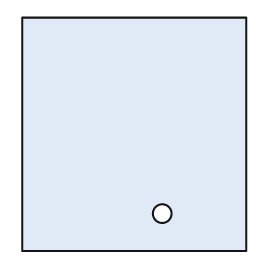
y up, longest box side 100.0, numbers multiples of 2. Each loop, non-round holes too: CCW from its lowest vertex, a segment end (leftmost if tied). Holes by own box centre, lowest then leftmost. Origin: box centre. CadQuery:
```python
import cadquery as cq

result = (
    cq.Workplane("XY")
    .moveTo(-48.0, -50.0)
    .lineTo(48.0, -50.0)
    .lineTo(48.0, 50.0)
    .lineTo(-48.0, 50.0)
    .close()
    .moveTo(12.0, -34.0)
    .circle(4.0)
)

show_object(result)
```